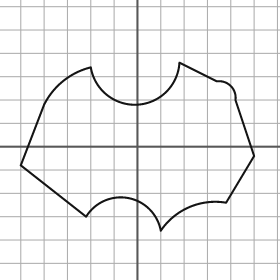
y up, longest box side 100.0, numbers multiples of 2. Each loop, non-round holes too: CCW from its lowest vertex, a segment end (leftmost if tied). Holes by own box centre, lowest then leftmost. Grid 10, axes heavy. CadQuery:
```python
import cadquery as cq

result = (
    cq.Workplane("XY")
    .moveTo(10.0, -36.0)
    .threePointArc((22.0, -26.0), (38.0, -24.0))
    .lineTo(50.0, -4.0)
    .lineTo(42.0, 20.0)
    .threePointArc((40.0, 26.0), (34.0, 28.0))
    .lineTo(18.0, 36.0)
    .threePointArc((0.0, 18.0), (-20.0, 34.0))
    .threePointArc((-32.0, 28.0), (-40.0, 18.0))
    .lineTo(-50.0, -8.0)
    .lineTo(-22.0, -30.0)
    .threePointArc((-4.0, -22.0), (10.0, -36.0))
    .close()
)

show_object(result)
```